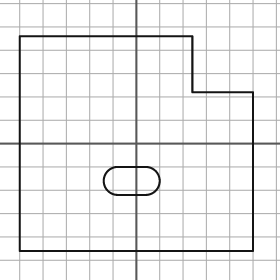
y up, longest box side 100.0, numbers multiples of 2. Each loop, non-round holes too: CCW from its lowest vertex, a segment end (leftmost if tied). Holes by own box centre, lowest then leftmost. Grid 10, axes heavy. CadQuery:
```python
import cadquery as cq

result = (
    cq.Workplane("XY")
    .moveTo(-50.0, -46.0)
    .lineTo(50.0, -46.0)
    .lineTo(50.0, 22.0)
    .lineTo(24.0, 22.0)
    .lineTo(24.0, 46.0)
    .lineTo(-50.0, 46.0)
    .close()
    .moveTo(-8.0, -22.0)
    .lineTo(4.0, -22.0)
    .threePointArc((10.0, -16.0), (4.0, -10.0))
    .lineTo(-8.0, -10.0)
    .threePointArc((-14.0, -16.0), (-8.0, -22.0))
    .close()
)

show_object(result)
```